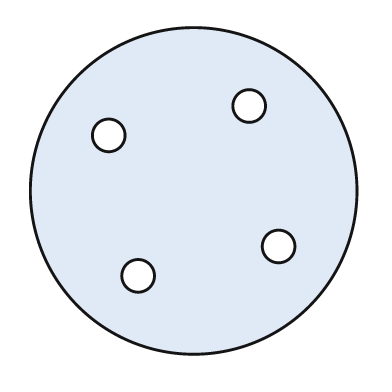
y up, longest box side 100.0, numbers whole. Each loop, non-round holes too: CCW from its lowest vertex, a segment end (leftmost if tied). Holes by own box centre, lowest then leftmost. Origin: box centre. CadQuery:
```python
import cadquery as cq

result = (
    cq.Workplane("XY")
    .moveTo(0.0, 0.0)
    .circle(50.0)
    .moveTo(-17.0, -26.0)
    .circle(5.0)
    .moveTo(26.0, -17.0)
    .circle(5.0)
    .moveTo(-26.0, 17.0)
    .circle(5.0)
    .moveTo(17.0, 26.0)
    .circle(5.0)
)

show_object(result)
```